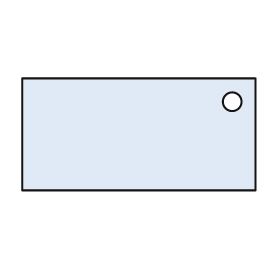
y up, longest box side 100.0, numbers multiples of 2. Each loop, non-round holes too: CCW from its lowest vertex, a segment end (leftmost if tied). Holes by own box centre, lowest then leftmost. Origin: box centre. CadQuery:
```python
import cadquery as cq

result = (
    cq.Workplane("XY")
    .moveTo(-50.0, -24.0)
    .lineTo(50.0, -24.0)
    .lineTo(50.0, 24.0)
    .lineTo(-50.0, 24.0)
    .close()
    .moveTo(40.0, 14.0)
    .circle(4.0)
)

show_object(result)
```